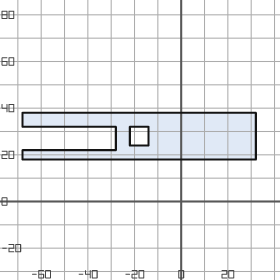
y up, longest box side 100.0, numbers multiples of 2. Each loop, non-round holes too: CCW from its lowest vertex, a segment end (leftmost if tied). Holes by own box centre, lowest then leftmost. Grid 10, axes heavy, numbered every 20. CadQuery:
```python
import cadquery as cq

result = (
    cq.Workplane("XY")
    .moveTo(-68.0, 18.0)
    .lineTo(32.0, 18.0)
    .lineTo(32.0, 38.0)
    .lineTo(-68.0, 38.0)
    .lineTo(-68.0, 32.0)
    .lineTo(-28.0, 32.0)
    .lineTo(-28.0, 22.0)
    .lineTo(-68.0, 22.0)
    .close()
    .moveTo(-22.0, 24.0)
    .lineTo(-14.0, 24.0)
    .lineTo(-14.0, 32.0)
    .lineTo(-22.0, 32.0)
    .close()
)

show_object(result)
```